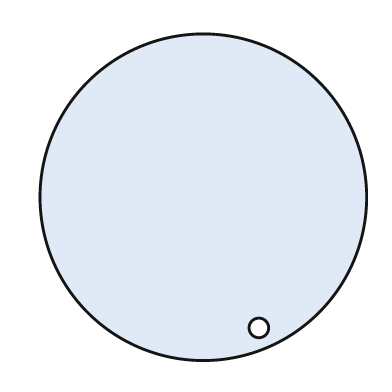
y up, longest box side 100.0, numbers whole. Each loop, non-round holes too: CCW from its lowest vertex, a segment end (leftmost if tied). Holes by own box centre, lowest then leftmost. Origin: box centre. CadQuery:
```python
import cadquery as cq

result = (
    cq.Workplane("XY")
    .moveTo(0.0, 0.0)
    .circle(50.0)
    .moveTo(17.0, -40.0)
    .circle(3.0)
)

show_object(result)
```